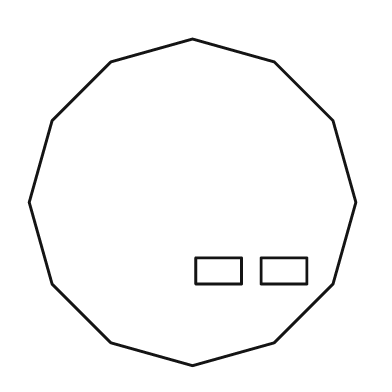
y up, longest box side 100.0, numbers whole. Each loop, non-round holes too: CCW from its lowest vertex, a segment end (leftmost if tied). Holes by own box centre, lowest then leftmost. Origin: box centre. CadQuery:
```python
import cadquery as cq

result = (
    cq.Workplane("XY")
    .moveTo(0.0, -50.0)
    .lineTo(25.0, -43.0)
    .lineTo(43.0, -25.0)
    .lineTo(50.0, 0.0)
    .lineTo(43.0, 25.0)
    .lineTo(25.0, 43.0)
    .lineTo(0.0, 50.0)
    .lineTo(-25.0, 43.0)
    .lineTo(-43.0, 25.0)
    .lineTo(-50.0, 0.0)
    .lineTo(-43.0, -25.0)
    .lineTo(-25.0, -43.0)
    .close()
    .moveTo(1.0, -25.0)
    .lineTo(15.0, -25.0)
    .lineTo(15.0, -17.0)
    .lineTo(1.0, -17.0)
    .close()
    .moveTo(21.0, -25.0)
    .lineTo(35.0, -25.0)
    .lineTo(35.0, -17.0)
    .lineTo(21.0, -17.0)
    .close()
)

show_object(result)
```